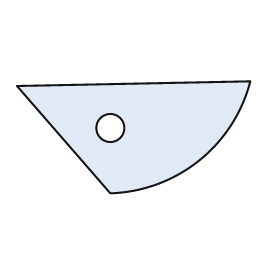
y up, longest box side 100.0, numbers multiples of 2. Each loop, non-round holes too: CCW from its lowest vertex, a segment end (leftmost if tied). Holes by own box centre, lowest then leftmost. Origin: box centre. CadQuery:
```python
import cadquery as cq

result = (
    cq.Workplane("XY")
    .moveTo(-10.0, -24.0)
    .threePointArc((28.0, -10.0), (50.0, 24.0))
    .lineTo(-50.0, 22.0)
    .close()
    .moveTo(-10.0, 4.0)
    .circle(6.0)
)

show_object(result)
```